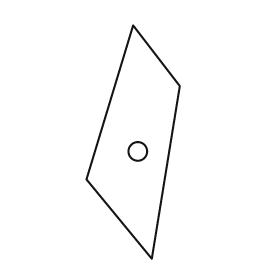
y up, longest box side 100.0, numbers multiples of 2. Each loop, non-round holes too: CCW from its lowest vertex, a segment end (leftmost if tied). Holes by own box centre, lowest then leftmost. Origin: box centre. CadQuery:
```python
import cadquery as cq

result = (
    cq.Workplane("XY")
    .moveTo(8.0, -50.0)
    .lineTo(20.0, 24.0)
    .lineTo(0.0, 50.0)
    .lineTo(-20.0, -16.0)
    .close()
    .moveTo(2.0, -4.0)
    .circle(4.0)
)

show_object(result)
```